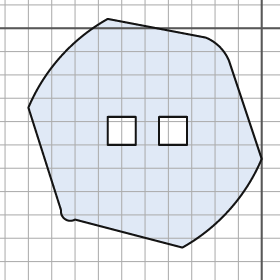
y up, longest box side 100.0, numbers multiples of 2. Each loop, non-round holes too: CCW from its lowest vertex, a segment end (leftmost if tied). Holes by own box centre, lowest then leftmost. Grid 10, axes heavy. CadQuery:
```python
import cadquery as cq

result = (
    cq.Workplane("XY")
    .moveTo(-34.0, -94.0)
    .threePointArc((-14.0, -78.0), (0.0, -56.0))
    .lineTo(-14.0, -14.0)
    .threePointArc((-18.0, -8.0), (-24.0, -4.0))
    .lineTo(-66.0, 4.0)
    .threePointArc((-86.0, -12.0), (-100.0, -34.0))
    .lineTo(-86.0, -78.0)
    .threePointArc((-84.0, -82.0), (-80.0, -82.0))
    .close()
    .moveTo(-66.0, -50.0)
    .lineTo(-54.0, -50.0)
    .lineTo(-54.0, -38.0)
    .lineTo(-66.0, -38.0)
    .close()
    .moveTo(-44.0, -50.0)
    .lineTo(-32.0, -50.0)
    .lineTo(-32.0, -38.0)
    .lineTo(-44.0, -38.0)
    .close()
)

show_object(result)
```